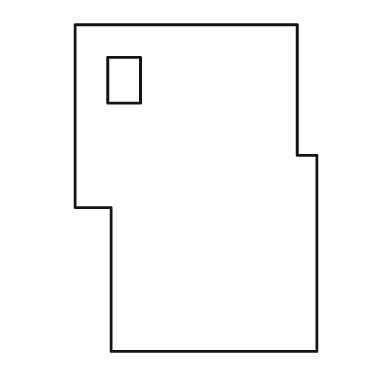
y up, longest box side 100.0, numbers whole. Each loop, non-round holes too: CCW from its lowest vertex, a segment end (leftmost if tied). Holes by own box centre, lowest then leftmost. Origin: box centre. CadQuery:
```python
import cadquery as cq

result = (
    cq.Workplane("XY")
    .moveTo(-26.0, -50.0)
    .lineTo(37.0, -50.0)
    .lineTo(37.0, 10.0)
    .lineTo(31.0, 10.0)
    .lineTo(31.0, 50.0)
    .lineTo(-37.0, 50.0)
    .lineTo(-37.0, -6.0)
    .lineTo(-26.0, -6.0)
    .close()
    .moveTo(-27.0, 26.0)
    .lineTo(-17.0, 26.0)
    .lineTo(-17.0, 40.0)
    .lineTo(-27.0, 40.0)
    .close()
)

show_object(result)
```